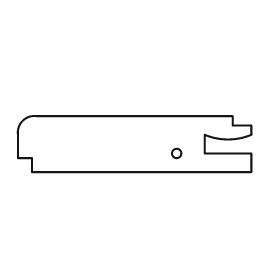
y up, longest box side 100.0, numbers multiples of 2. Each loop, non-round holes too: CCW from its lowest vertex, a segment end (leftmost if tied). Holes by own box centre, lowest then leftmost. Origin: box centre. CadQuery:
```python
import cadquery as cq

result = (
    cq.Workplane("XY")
    .moveTo(-44.0, -12.0)
    .lineTo(50.0, -12.0)
    .lineTo(50.0, -4.0)
    .lineTo(30.0, -4.0)
    .lineTo(30.0, 4.0)
    .threePointArc((40.0, 2.0), (50.0, 4.0))
    .lineTo(50.0, 8.0)
    .lineTo(42.0, 8.0)
    .lineTo(42.0, 12.0)
    .lineTo(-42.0, 12.0)
    .threePointArc((-48.0, 10.0), (-50.0, 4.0))
    .lineTo(-50.0, -6.0)
    .lineTo(-44.0, -6.0)
    .close()
    .moveTo(18.0, -4.0)
    .circle(2.0)
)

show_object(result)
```